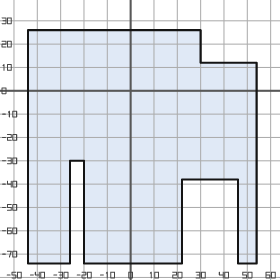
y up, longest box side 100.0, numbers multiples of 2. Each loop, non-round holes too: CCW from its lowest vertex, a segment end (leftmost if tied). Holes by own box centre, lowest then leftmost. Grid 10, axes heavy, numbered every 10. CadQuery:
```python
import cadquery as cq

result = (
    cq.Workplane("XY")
    .moveTo(-44.0, -74.0)
    .lineTo(-26.0, -74.0)
    .lineTo(-26.0, -30.0)
    .lineTo(-20.0, -30.0)
    .lineTo(-20.0, -74.0)
    .lineTo(22.0, -74.0)
    .lineTo(22.0, -38.0)
    .lineTo(46.0, -38.0)
    .lineTo(46.0, -74.0)
    .lineTo(54.0, -74.0)
    .lineTo(54.0, 12.0)
    .lineTo(30.0, 12.0)
    .lineTo(30.0, 26.0)
    .lineTo(-44.0, 26.0)
    .close()
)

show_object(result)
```